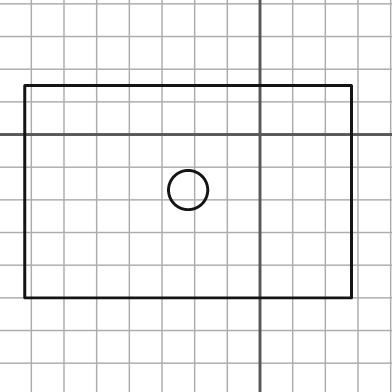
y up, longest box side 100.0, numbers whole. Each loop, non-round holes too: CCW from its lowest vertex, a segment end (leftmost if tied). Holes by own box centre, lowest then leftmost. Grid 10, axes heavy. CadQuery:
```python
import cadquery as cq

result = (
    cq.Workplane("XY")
    .moveTo(-72.0, -50.0)
    .lineTo(28.0, -50.0)
    .lineTo(28.0, 15.0)
    .lineTo(-72.0, 15.0)
    .close()
    .moveTo(-22.0, -17.0)
    .circle(6.0)
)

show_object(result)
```